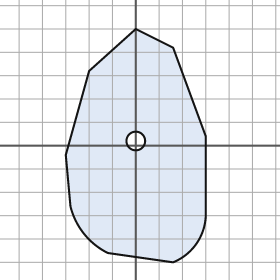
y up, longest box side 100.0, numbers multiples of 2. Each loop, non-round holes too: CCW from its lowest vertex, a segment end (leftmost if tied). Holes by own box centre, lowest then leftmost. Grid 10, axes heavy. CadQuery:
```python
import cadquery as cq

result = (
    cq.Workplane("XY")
    .moveTo(16.0, -50.0)
    .threePointArc((26.0, -42.0), (30.0, -30.0))
    .lineTo(30.0, 4.0)
    .lineTo(16.0, 42.0)
    .lineTo(0.0, 50.0)
    .lineTo(-20.0, 32.0)
    .lineTo(-30.0, -4.0)
    .lineTo(-28.0, -26.0)
    .threePointArc((-22.0, -38.0), (-12.0, -46.0))
    .close()
    .moveTo(0.0, 2.0)
    .circle(4.0)
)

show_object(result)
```